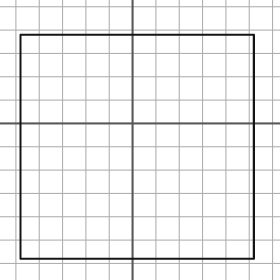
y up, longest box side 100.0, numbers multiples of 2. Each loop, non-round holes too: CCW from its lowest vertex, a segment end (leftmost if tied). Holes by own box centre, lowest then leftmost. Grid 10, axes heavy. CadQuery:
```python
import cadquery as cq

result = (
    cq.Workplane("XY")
    .moveTo(-48.0, -58.0)
    .lineTo(52.0, -58.0)
    .lineTo(52.0, 38.0)
    .lineTo(-48.0, 38.0)
    .close()
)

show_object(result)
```